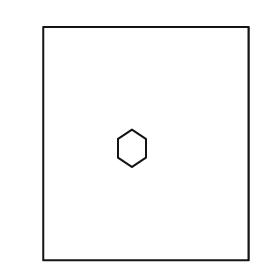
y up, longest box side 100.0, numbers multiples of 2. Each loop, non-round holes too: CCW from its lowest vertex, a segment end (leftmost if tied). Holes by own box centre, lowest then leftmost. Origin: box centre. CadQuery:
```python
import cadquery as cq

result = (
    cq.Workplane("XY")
    .moveTo(-44.0, -50.0)
    .lineTo(44.0, -50.0)
    .lineTo(44.0, 50.0)
    .lineTo(-44.0, 50.0)
    .close()
    .moveTo(-6.0, -10.0)
    .lineTo(0.0, -6.0)
    .lineTo(0.0, 2.0)
    .lineTo(-6.0, 6.0)
    .lineTo(-12.0, 2.0)
    .lineTo(-12.0, -6.0)
    .close()
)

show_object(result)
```